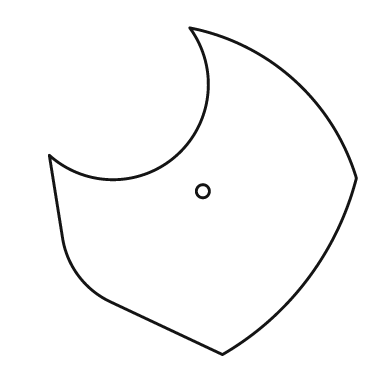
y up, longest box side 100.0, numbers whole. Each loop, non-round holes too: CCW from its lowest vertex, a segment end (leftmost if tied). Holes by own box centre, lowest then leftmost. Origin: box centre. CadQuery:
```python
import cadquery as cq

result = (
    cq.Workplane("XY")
    .moveTo(6.0, -50.0)
    .threePointArc((32.0, -27.0), (47.0, 4.0))
    .threePointArc((28.0, 34.0), (-4.0, 50.0))
    .threePointArc((-8.0, 11.0), (-47.0, 11.0))
    .lineTo(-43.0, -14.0)
    .threePointArc((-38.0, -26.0), (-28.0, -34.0))
    .close()
    .moveTo(0.0, 0.0)
    .circle(2.0)
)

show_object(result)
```